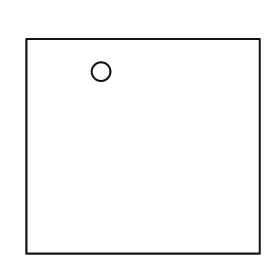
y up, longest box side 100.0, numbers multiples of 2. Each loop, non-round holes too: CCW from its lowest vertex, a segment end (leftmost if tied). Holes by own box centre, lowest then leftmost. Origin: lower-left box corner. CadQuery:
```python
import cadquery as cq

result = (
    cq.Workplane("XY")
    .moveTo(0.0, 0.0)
    .lineTo(100.0, 0.0)
    .lineTo(100.0, 92.0)
    .lineTo(0.0, 92.0)
    .close()
    .moveTo(32.0, 78.0)
    .circle(4.0)
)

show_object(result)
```